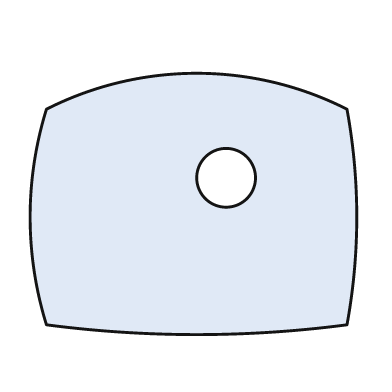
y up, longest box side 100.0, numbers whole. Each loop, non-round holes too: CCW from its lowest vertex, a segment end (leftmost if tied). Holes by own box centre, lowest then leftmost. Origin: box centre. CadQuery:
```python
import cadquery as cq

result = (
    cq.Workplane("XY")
    .moveTo(-45.0, -37.0)
    .threePointArc((1.0, -40.0), (47.0, -37.0))
    .threePointArc((50.0, -4.0), (47.0, 29.0))
    .threePointArc((1.0, 40.0), (-45.0, 29.0))
    .threePointArc((-50.0, -4.0), (-45.0, -37.0))
    .close()
    .moveTo(10.0, 8.0)
    .circle(9.0)
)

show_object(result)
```